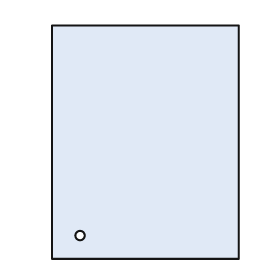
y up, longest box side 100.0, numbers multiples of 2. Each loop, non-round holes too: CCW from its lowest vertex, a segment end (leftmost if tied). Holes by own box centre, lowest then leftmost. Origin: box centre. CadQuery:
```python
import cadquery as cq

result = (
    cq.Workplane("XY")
    .moveTo(-40.0, -50.0)
    .lineTo(40.0, -50.0)
    .lineTo(40.0, 50.0)
    .lineTo(-40.0, 50.0)
    .close()
    .moveTo(-28.0, -40.0)
    .circle(2.0)
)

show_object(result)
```